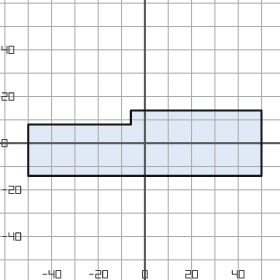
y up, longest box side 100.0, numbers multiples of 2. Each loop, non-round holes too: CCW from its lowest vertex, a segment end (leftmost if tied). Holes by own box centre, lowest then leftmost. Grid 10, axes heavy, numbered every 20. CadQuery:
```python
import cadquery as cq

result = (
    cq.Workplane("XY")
    .moveTo(-50.0, -14.0)
    .lineTo(50.0, -14.0)
    .lineTo(50.0, 14.0)
    .lineTo(-6.0, 14.0)
    .lineTo(-6.0, 8.0)
    .lineTo(-50.0, 8.0)
    .close()
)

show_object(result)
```